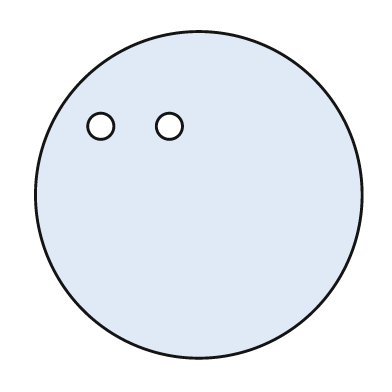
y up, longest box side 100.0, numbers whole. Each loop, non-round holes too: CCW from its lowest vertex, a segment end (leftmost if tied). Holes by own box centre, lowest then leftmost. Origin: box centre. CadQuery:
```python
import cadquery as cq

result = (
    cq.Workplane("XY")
    .moveTo(0.0, 0.0)
    .circle(50.0)
    .moveTo(-30.0, 21.0)
    .circle(4.0)
    .moveTo(-9.0, 21.0)
    .circle(4.0)
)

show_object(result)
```